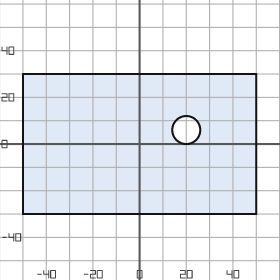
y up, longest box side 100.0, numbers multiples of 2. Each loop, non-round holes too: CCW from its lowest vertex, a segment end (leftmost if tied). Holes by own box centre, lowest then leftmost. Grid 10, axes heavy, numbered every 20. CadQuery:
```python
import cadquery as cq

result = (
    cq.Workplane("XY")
    .moveTo(-50.0, -30.0)
    .lineTo(50.0, -30.0)
    .lineTo(50.0, 30.0)
    .lineTo(-50.0, 30.0)
    .close()
    .moveTo(20.0, 6.0)
    .circle(6.0)
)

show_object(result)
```